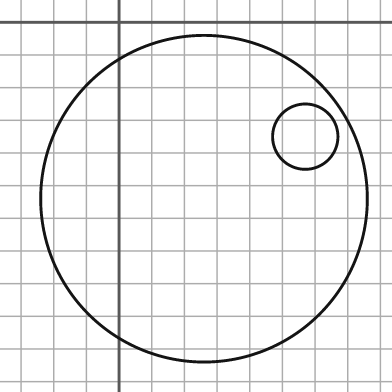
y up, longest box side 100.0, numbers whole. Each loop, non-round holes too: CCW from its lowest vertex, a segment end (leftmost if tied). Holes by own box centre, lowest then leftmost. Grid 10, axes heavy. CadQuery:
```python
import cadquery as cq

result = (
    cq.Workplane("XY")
    .moveTo(26.0, -54.0)
    .circle(50.0)
    .moveTo(57.0, -35.0)
    .circle(10.0)
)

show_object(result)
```